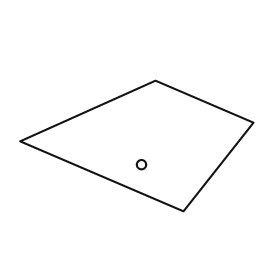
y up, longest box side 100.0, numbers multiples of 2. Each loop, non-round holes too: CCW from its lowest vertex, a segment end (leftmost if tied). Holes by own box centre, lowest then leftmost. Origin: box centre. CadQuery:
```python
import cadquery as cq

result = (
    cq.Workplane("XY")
    .moveTo(20.0, -28.0)
    .lineTo(50.0, 10.0)
    .lineTo(8.0, 28.0)
    .lineTo(-50.0, 2.0)
    .close()
    .moveTo(2.0, -8.0)
    .circle(2.0)
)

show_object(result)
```